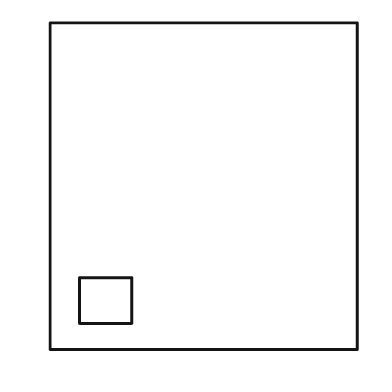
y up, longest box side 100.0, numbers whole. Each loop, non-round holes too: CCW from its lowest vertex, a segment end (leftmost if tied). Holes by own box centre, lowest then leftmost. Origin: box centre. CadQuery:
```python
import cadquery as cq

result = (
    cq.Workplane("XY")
    .moveTo(-47.0, -50.0)
    .lineTo(47.0, -50.0)
    .lineTo(47.0, 50.0)
    .lineTo(-47.0, 50.0)
    .close()
    .moveTo(-38.0, -42.0)
    .lineTo(-22.0, -42.0)
    .lineTo(-22.0, -28.0)
    .lineTo(-38.0, -28.0)
    .close()
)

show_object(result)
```